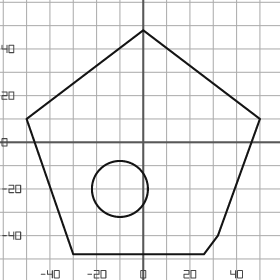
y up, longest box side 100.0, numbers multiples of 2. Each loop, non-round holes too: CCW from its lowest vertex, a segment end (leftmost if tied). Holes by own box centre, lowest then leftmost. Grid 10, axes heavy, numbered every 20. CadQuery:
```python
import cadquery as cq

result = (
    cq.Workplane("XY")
    .moveTo(-30.0, -48.0)
    .lineTo(26.0, -48.0)
    .lineTo(32.0, -40.0)
    .lineTo(50.0, 10.0)
    .lineTo(0.0, 48.0)
    .lineTo(-50.0, 10.0)
    .close()
    .moveTo(-10.0, -20.0)
    .circle(12.0)
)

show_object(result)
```